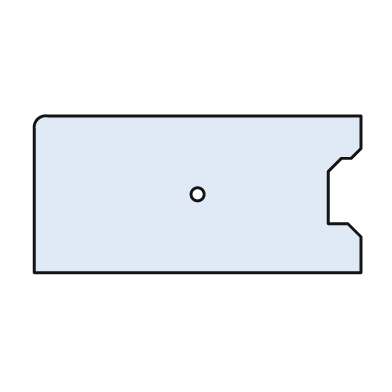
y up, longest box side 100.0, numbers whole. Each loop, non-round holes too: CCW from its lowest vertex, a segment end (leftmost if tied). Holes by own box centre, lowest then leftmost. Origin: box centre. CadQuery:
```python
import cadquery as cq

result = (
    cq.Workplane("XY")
    .moveTo(-50.0, -24.0)
    .lineTo(50.0, -24.0)
    .lineTo(50.0, -13.0)
    .lineTo(46.0, -9.0)
    .lineTo(40.0, -9.0)
    .lineTo(40.0, 7.0)
    .lineTo(44.0, 11.0)
    .lineTo(47.0, 11.0)
    .lineTo(50.0, 14.0)
    .lineTo(50.0, 24.0)
    .lineTo(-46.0, 24.0)
    .threePointArc((-49.0, 23.0), (-50.0, 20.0))
    .close()
    .moveTo(0.0, 0.0)
    .circle(2.0)
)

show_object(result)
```